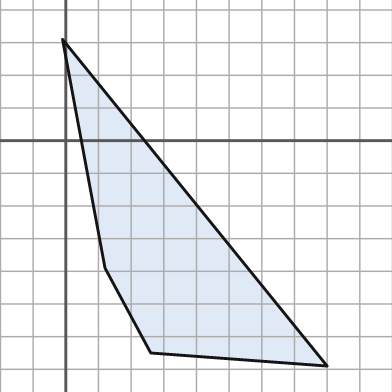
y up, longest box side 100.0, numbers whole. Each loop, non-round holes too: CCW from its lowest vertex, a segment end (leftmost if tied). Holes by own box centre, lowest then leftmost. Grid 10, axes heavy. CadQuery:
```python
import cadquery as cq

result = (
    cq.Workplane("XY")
    .moveTo(80.0, -69.0)
    .lineTo(-1.0, 31.0)
    .lineTo(12.0, -39.0)
    .lineTo(26.0, -65.0)
    .close()
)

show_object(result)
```